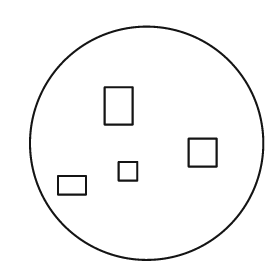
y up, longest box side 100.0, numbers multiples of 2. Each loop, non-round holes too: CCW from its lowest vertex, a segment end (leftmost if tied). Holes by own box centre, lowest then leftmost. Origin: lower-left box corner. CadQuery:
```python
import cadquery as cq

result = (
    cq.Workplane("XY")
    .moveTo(50.0, 50.0)
    .circle(50.0)
    .moveTo(12.0, 28.0)
    .lineTo(24.0, 28.0)
    .lineTo(24.0, 36.0)
    .lineTo(12.0, 36.0)
    .close()
    .moveTo(38.0, 34.0)
    .lineTo(46.0, 34.0)
    .lineTo(46.0, 42.0)
    .lineTo(38.0, 42.0)
    .close()
    .moveTo(68.0, 40.0)
    .lineTo(80.0, 40.0)
    .lineTo(80.0, 52.0)
    .lineTo(68.0, 52.0)
    .close()
    .moveTo(32.0, 58.0)
    .lineTo(44.0, 58.0)
    .lineTo(44.0, 74.0)
    .lineTo(32.0, 74.0)
    .close()
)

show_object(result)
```